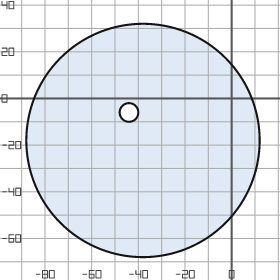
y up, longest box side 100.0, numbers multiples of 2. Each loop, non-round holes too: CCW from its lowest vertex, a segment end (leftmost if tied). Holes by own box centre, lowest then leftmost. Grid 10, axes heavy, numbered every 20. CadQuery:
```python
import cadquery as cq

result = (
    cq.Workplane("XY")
    .moveTo(-38.0, -18.0)
    .circle(50.0)
    .moveTo(-44.0, -6.0)
    .circle(4.0)
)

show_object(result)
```